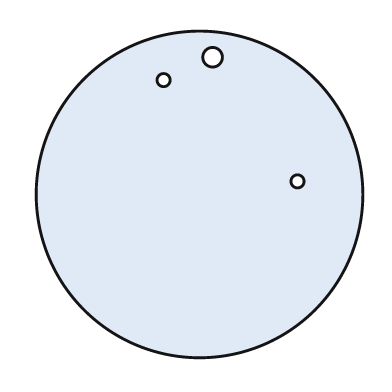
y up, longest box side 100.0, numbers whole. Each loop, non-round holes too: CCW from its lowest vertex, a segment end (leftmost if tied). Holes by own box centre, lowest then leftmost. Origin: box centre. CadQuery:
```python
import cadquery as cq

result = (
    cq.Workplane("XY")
    .moveTo(0.0, 0.0)
    .circle(50.0)
    .moveTo(30.0, 4.0)
    .circle(2.0)
    .moveTo(-11.0, 35.0)
    .circle(2.0)
    .moveTo(4.0, 42.0)
    .circle(3.0)
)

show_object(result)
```